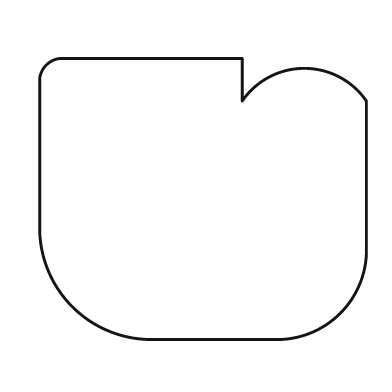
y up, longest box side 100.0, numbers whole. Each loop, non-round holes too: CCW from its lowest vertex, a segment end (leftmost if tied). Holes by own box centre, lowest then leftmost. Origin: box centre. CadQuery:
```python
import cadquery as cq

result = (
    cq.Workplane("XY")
    .moveTo(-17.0, -43.0)
    .lineTo(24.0, -43.0)
    .threePointArc((42.0, -35.0), (50.0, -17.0))
    .lineTo(50.0, 30.0)
    .threePointArc((31.0, 40.0), (12.0, 30.0))
    .lineTo(12.0, 43.0)
    .lineTo(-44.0, 43.0)
    .threePointArc((-48.0, 41.0), (-50.0, 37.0))
    .lineTo(-50.0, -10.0)
    .threePointArc((-40.0, -33.0), (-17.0, -43.0))
    .close()
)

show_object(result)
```